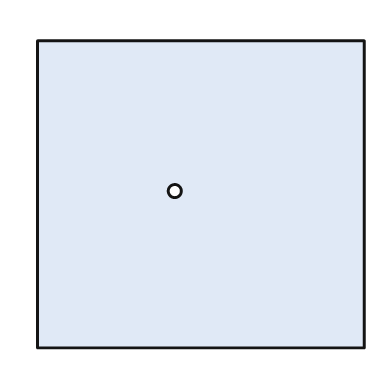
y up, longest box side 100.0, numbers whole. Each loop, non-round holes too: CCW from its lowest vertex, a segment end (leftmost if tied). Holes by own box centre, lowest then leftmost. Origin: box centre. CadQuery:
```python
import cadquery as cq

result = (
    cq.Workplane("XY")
    .moveTo(-50.0, -47.0)
    .lineTo(50.0, -47.0)
    .lineTo(50.0, 47.0)
    .lineTo(-50.0, 47.0)
    .close()
    .moveTo(-8.0, 1.0)
    .circle(2.0)
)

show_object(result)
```